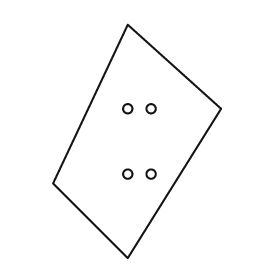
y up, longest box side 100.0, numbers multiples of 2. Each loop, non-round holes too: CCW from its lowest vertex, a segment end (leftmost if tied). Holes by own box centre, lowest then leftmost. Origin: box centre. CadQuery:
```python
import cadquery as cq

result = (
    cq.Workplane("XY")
    .moveTo(-4.0, -50.0)
    .lineTo(36.0, 14.0)
    .lineTo(-4.0, 50.0)
    .lineTo(-36.0, -18.0)
    .close()
    .moveTo(-4.0, -14.0)
    .circle(2.0)
    .moveTo(6.0, -14.0)
    .circle(2.0)
    .moveTo(-4.0, 14.0)
    .circle(2.0)
    .moveTo(6.0, 14.0)
    .circle(2.0)
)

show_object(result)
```